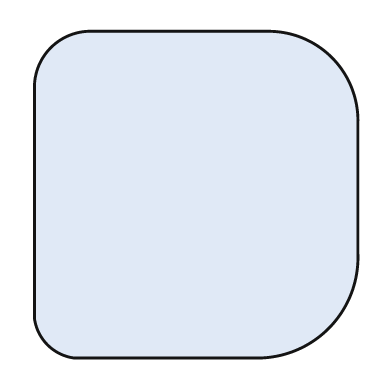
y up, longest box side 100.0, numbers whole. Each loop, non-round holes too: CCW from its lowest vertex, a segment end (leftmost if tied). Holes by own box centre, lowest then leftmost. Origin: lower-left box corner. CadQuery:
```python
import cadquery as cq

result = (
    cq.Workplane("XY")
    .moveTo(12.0, 0.0)
    .lineTo(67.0, 0.0)
    .threePointArc((90.0, 9.0), (99.0, 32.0))
    .lineTo(99.0, 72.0)
    .threePointArc((91.0, 92.0), (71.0, 100.0))
    .lineTo(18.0, 100.0)
    .threePointArc((5.0, 95.0), (0.0, 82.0))
    .lineTo(0.0, 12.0)
    .threePointArc((4.0, 4.0), (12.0, 0.0))
    .close()
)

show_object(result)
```